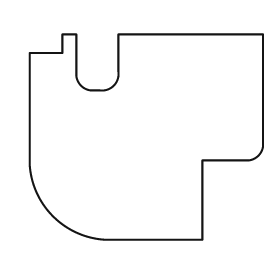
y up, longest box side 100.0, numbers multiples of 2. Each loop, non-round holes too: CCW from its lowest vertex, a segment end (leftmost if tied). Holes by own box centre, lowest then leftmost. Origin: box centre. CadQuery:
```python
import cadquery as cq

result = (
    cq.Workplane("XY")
    .moveTo(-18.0, -44.0)
    .lineTo(24.0, -44.0)
    .lineTo(24.0, -10.0)
    .lineTo(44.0, -10.0)
    .threePointArc((48.0, -8.0), (50.0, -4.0))
    .lineTo(50.0, 44.0)
    .lineTo(-12.0, 44.0)
    .lineTo(-12.0, 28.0)
    .threePointArc((-14.0, 22.0), (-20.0, 20.0))
    .lineTo(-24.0, 20.0)
    .threePointArc((-28.0, 22.0), (-30.0, 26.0))
    .lineTo(-30.0, 44.0)
    .lineTo(-36.0, 44.0)
    .lineTo(-36.0, 36.0)
    .lineTo(-50.0, 36.0)
    .lineTo(-50.0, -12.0)
    .threePointArc((-40.0, -34.0), (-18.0, -44.0))
    .close()
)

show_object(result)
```